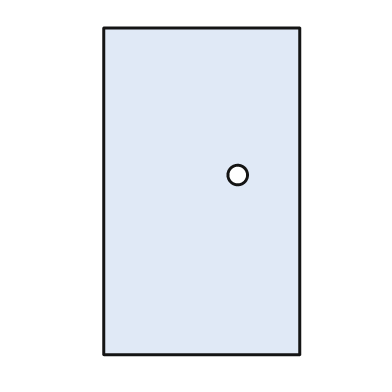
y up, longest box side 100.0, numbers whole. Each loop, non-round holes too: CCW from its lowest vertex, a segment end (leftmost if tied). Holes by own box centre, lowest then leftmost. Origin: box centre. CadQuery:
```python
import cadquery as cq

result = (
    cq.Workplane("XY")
    .moveTo(-30.0, -50.0)
    .lineTo(30.0, -50.0)
    .lineTo(30.0, 50.0)
    .lineTo(-30.0, 50.0)
    .close()
    .moveTo(11.0, 5.0)
    .circle(3.0)
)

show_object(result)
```